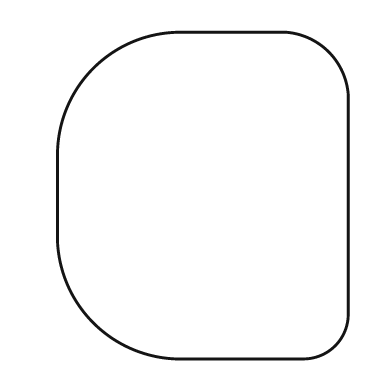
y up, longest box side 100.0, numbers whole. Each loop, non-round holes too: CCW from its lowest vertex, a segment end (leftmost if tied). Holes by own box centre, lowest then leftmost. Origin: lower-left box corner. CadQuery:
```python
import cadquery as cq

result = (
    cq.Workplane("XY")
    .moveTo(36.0, 0.0)
    .lineTo(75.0, 0.0)
    .threePointArc((85.0, 4.0), (89.0, 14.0))
    .lineTo(89.0, 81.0)
    .threePointArc((83.0, 94.0), (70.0, 100.0))
    .lineTo(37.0, 100.0)
    .threePointArc((11.0, 89.0), (0.0, 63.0))
    .lineTo(0.0, 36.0)
    .threePointArc((11.0, 11.0), (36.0, 0.0))
    .close()
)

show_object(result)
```